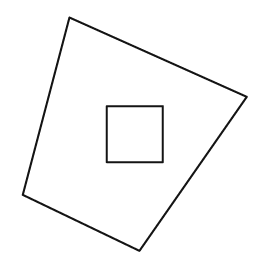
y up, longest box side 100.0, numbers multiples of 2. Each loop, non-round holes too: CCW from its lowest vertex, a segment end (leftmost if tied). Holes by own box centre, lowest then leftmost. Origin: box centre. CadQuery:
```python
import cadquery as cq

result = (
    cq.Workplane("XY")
    .moveTo(2.0, -50.0)
    .lineTo(48.0, 16.0)
    .lineTo(-28.0, 50.0)
    .lineTo(-48.0, -26.0)
    .close()
    .moveTo(-12.0, -12.0)
    .lineTo(12.0, -12.0)
    .lineTo(12.0, 12.0)
    .lineTo(-12.0, 12.0)
    .close()
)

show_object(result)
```